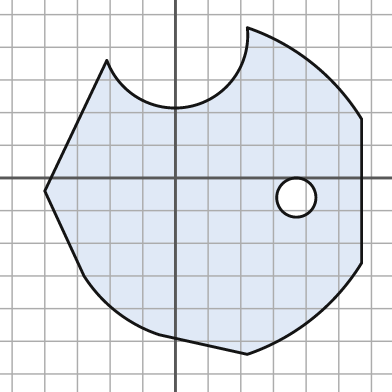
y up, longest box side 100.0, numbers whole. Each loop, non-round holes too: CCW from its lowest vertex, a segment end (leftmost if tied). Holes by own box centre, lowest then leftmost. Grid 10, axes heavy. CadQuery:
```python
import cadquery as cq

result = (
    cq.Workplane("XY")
    .moveTo(22.0, -54.0)
    .threePointArc((42.0, -43.0), (57.0, -26.0))
    .lineTo(57.0, 18.0)
    .threePointArc((42.0, 35.0), (22.0, 46.0))
    .threePointArc((5.0, 22.0), (-21.0, 36.0))
    .lineTo(-40.0, -4.0)
    .lineTo(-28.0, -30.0)
    .threePointArc((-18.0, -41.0), (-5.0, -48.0))
    .close()
    .moveTo(37.0, -6.0)
    .circle(6.0)
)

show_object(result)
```